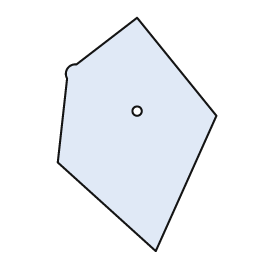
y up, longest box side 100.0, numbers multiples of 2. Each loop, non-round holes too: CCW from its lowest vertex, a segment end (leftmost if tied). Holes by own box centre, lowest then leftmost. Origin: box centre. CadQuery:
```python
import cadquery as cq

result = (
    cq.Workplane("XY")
    .moveTo(8.0, -50.0)
    .lineTo(34.0, 8.0)
    .lineTo(0.0, 50.0)
    .lineTo(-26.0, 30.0)
    .threePointArc((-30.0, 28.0), (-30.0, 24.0))
    .lineTo(-34.0, -12.0)
    .close()
    .moveTo(0.0, 10.0)
    .circle(2.0)
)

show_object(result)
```